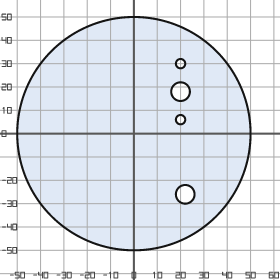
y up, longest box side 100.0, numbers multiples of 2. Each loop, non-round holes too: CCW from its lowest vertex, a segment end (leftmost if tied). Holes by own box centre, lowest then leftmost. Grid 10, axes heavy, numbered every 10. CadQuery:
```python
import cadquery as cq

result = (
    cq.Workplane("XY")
    .moveTo(0.0, 0.0)
    .circle(50.0)
    .moveTo(22.0, -26.0)
    .circle(4.0)
    .moveTo(20.0, 6.0)
    .circle(2.0)
    .moveTo(20.0, 18.0)
    .circle(4.0)
    .moveTo(20.0, 30.0)
    .circle(2.0)
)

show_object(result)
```